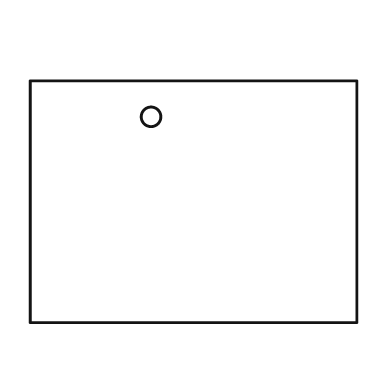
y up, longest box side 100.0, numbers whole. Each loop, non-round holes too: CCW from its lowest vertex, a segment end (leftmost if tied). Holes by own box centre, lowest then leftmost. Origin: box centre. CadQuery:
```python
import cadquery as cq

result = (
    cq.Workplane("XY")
    .moveTo(-50.0, -37.0)
    .lineTo(50.0, -37.0)
    .lineTo(50.0, 37.0)
    .lineTo(-50.0, 37.0)
    .close()
    .moveTo(-13.0, 26.0)
    .circle(3.0)
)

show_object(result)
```